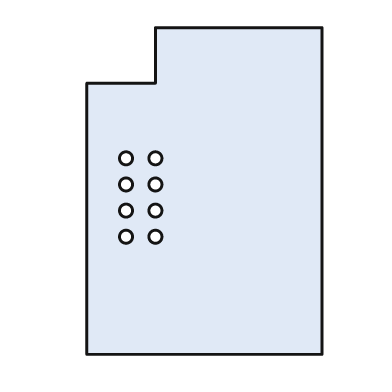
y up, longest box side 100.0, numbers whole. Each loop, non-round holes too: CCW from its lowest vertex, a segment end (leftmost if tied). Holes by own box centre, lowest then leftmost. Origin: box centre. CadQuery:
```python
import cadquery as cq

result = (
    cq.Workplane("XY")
    .moveTo(-36.0, -50.0)
    .lineTo(36.0, -50.0)
    .lineTo(36.0, 50.0)
    .lineTo(-15.0, 50.0)
    .lineTo(-15.0, 33.0)
    .lineTo(-36.0, 33.0)
    .close()
    .moveTo(-24.0, -14.0)
    .circle(2.0)
    .moveTo(-15.0, -14.0)
    .circle(2.0)
    .moveTo(-24.0, -6.0)
    .circle(2.0)
    .moveTo(-15.0, -6.0)
    .circle(2.0)
    .moveTo(-24.0, 2.0)
    .circle(2.0)
    .moveTo(-15.0, 2.0)
    .circle(2.0)
    .moveTo(-24.0, 10.0)
    .circle(2.0)
    .moveTo(-15.0, 10.0)
    .circle(2.0)
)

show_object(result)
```